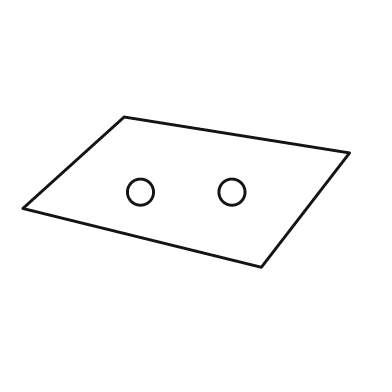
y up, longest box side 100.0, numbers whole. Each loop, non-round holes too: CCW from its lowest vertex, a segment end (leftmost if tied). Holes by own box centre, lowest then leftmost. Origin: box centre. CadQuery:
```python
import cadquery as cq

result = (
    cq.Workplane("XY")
    .moveTo(23.0, -23.0)
    .lineTo(50.0, 12.0)
    .lineTo(-19.0, 23.0)
    .lineTo(-50.0, -5.0)
    .close()
    .moveTo(-14.0, 0.0)
    .circle(4.0)
    .moveTo(14.0, 0.0)
    .circle(4.0)
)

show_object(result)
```